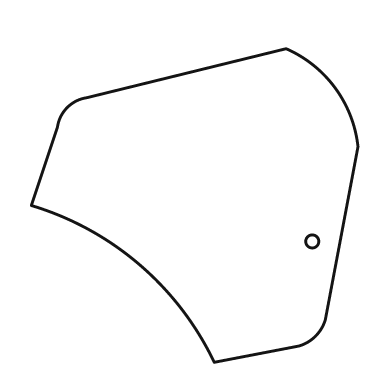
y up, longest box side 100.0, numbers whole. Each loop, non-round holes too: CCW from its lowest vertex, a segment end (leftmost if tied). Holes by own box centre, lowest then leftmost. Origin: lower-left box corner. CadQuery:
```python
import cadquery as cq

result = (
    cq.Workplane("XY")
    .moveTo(56.0, 0.0)
    .lineTo(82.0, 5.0)
    .threePointArc((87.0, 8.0), (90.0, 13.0))
    .lineTo(100.0, 66.0)
    .threePointArc((93.0, 84.0), (78.0, 96.0))
    .lineTo(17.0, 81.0)
    .threePointArc((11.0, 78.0), (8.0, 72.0))
    .lineTo(0.0, 48.0)
    .threePointArc((33.0, 30.0), (56.0, 0.0))
    .close()
    .moveTo(86.0, 37.0)
    .circle(2.0)
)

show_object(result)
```